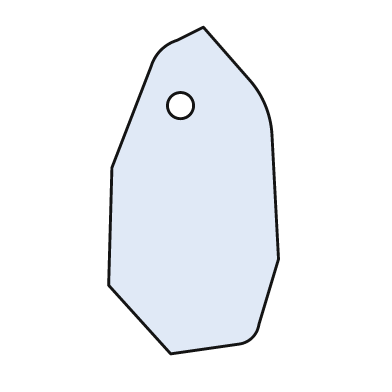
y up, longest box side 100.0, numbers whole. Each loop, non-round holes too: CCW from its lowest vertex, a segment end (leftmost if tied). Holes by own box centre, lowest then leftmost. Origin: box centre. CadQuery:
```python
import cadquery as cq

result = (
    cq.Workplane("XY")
    .moveTo(-7.0, -50.0)
    .lineTo(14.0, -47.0)
    .threePointArc((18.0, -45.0), (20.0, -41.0))
    .lineTo(26.0, -21.0)
    .lineTo(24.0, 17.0)
    .threePointArc((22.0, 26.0), (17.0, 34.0))
    .lineTo(3.0, 50.0)
    .lineTo(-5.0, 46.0)
    .threePointArc((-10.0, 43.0), (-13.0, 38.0))
    .lineTo(-25.0, 7.0)
    .lineTo(-26.0, -29.0)
    .close()
    .moveTo(-4.0, 26.0)
    .circle(4.0)
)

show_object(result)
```